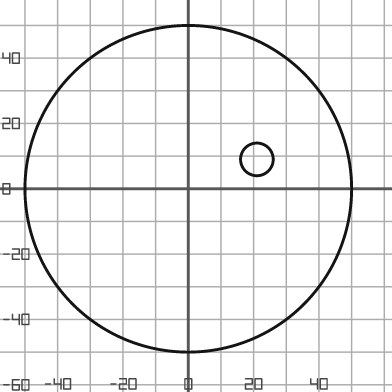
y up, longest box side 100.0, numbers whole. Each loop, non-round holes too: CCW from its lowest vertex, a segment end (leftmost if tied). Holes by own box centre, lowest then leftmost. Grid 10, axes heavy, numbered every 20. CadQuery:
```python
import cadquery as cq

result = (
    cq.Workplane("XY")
    .moveTo(0.0, 0.0)
    .circle(50.0)
    .moveTo(21.0, 9.0)
    .circle(5.0)
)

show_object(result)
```